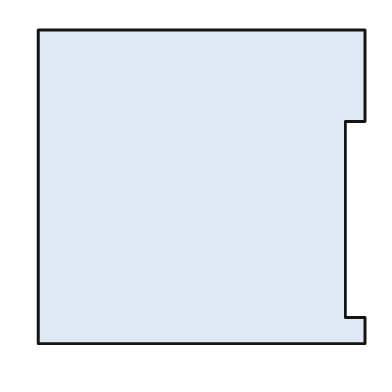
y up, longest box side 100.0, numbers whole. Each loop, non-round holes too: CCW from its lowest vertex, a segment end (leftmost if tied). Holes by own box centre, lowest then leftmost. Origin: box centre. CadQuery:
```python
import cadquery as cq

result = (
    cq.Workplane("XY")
    .moveTo(-50.0, -48.0)
    .lineTo(50.0, -48.0)
    .lineTo(50.0, -40.0)
    .lineTo(44.0, -40.0)
    .lineTo(44.0, 20.0)
    .lineTo(50.0, 20.0)
    .lineTo(50.0, 48.0)
    .lineTo(-50.0, 48.0)
    .close()
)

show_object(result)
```